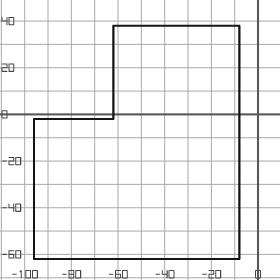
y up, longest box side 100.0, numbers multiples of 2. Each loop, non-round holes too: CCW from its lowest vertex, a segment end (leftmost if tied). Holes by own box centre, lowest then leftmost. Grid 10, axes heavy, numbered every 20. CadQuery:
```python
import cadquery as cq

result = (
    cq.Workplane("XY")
    .moveTo(-96.0, -62.0)
    .lineTo(-8.0, -62.0)
    .lineTo(-8.0, 38.0)
    .lineTo(-62.0, 38.0)
    .lineTo(-62.0, -2.0)
    .lineTo(-96.0, -2.0)
    .close()
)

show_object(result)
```